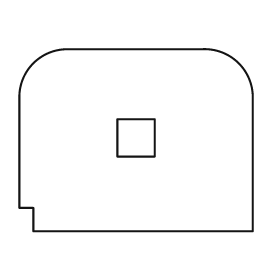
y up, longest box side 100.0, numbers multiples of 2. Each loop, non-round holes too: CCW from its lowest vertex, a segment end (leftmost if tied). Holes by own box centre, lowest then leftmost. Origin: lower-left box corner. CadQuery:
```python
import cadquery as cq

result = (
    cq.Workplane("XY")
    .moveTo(6.0, 0.0)
    .lineTo(100.0, 0.0)
    .lineTo(100.0, 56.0)
    .threePointArc((94.0, 72.0), (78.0, 78.0))
    .lineTo(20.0, 78.0)
    .threePointArc((6.0, 72.0), (0.0, 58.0))
    .lineTo(0.0, 10.0)
    .lineTo(6.0, 10.0)
    .close()
    .moveTo(42.0, 32.0)
    .lineTo(58.0, 32.0)
    .lineTo(58.0, 48.0)
    .lineTo(42.0, 48.0)
    .close()
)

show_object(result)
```